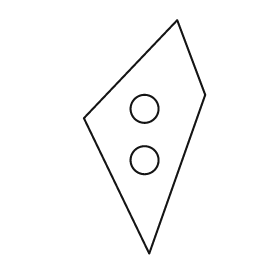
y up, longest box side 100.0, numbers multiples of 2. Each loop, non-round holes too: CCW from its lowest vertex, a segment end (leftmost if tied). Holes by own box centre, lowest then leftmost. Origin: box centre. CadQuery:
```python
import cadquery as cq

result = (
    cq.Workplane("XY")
    .moveTo(2.0, -50.0)
    .lineTo(26.0, 18.0)
    .lineTo(14.0, 50.0)
    .lineTo(-26.0, 8.0)
    .close()
    .moveTo(0.0, -10.0)
    .circle(6.0)
    .moveTo(0.0, 12.0)
    .circle(6.0)
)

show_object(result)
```